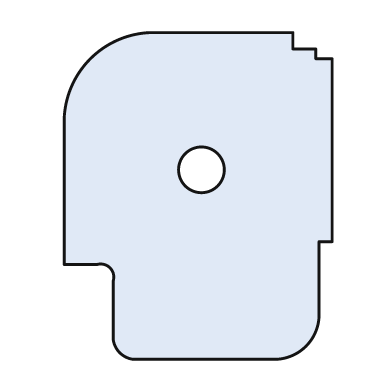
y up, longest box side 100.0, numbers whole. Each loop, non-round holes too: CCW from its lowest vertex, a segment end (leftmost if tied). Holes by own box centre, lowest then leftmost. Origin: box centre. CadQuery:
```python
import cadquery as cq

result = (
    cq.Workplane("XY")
    .moveTo(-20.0, -50.0)
    .lineTo(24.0, -50.0)
    .threePointArc((33.0, -46.0), (37.0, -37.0))
    .lineTo(37.0, -14.0)
    .lineTo(41.0, -14.0)
    .lineTo(41.0, 42.0)
    .lineTo(36.0, 42.0)
    .lineTo(36.0, 45.0)
    .lineTo(29.0, 45.0)
    .lineTo(29.0, 50.0)
    .lineTo(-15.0, 50.0)
    .threePointArc((-33.0, 42.0), (-41.0, 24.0))
    .lineTo(-41.0, -21.0)
    .lineTo(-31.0, -21.0)
    .threePointArc((-27.0, -22.0), (-26.0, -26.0))
    .lineTo(-26.0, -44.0)
    .threePointArc((-24.0, -48.0), (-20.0, -50.0))
    .close()
    .moveTo(1.0, 8.0)
    .circle(7.0)
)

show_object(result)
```